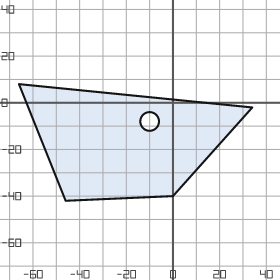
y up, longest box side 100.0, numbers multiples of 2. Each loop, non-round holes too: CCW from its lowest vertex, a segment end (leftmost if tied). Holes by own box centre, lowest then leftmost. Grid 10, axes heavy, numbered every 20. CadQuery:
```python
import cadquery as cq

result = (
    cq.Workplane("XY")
    .moveTo(-46.0, -42.0)
    .lineTo(0.0, -40.0)
    .lineTo(34.0, -2.0)
    .lineTo(-66.0, 8.0)
    .close()
    .moveTo(-10.0, -8.0)
    .circle(4.0)
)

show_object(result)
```